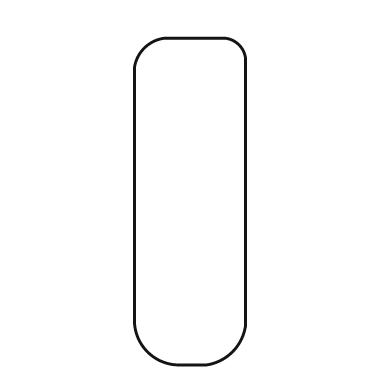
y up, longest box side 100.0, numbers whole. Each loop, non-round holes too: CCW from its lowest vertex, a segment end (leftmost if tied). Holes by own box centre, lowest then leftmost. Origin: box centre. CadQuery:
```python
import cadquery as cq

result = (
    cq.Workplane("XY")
    .moveTo(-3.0, -50.0)
    .lineTo(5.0, -50.0)
    .threePointArc((13.0, -46.0), (17.0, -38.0))
    .lineTo(17.0, 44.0)
    .threePointArc((15.0, 48.0), (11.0, 50.0))
    .lineTo(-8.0, 50.0)
    .threePointArc((-14.0, 47.0), (-17.0, 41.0))
    .lineTo(-17.0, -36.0)
    .threePointArc((-13.0, -46.0), (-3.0, -50.0))
    .close()
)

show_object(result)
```